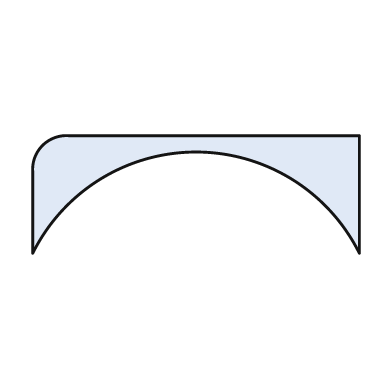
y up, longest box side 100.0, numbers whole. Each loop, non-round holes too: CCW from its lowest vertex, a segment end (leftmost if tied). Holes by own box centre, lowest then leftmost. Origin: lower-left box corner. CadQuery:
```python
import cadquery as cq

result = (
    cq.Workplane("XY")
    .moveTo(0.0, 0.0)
    .threePointArc((50.0, 31.0), (100.0, 0.0))
    .lineTo(100.0, 36.0)
    .lineTo(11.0, 36.0)
    .threePointArc((3.0, 33.0), (0.0, 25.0))
    .close()
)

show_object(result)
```